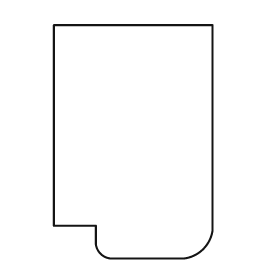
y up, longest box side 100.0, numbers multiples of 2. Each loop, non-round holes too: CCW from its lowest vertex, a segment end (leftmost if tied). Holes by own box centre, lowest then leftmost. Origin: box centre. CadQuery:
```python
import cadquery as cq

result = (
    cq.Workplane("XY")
    .moveTo(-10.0, -50.0)
    .lineTo(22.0, -50.0)
    .threePointArc((30.0, -46.0), (34.0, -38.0))
    .lineTo(34.0, 50.0)
    .lineTo(-34.0, 50.0)
    .lineTo(-34.0, -36.0)
    .lineTo(-16.0, -36.0)
    .lineTo(-16.0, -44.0)
    .threePointArc((-14.0, -48.0), (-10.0, -50.0))
    .close()
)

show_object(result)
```